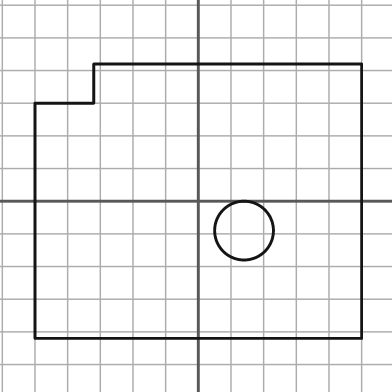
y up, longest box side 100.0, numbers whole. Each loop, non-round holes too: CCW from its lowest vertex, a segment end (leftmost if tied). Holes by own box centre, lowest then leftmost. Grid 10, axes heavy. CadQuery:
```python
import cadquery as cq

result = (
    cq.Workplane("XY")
    .moveTo(-50.0, -42.0)
    .lineTo(50.0, -42.0)
    .lineTo(50.0, 42.0)
    .lineTo(-32.0, 42.0)
    .lineTo(-32.0, 30.0)
    .lineTo(-50.0, 30.0)
    .close()
    .moveTo(14.0, -9.0)
    .circle(9.0)
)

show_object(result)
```